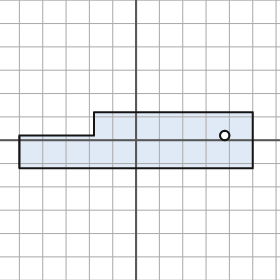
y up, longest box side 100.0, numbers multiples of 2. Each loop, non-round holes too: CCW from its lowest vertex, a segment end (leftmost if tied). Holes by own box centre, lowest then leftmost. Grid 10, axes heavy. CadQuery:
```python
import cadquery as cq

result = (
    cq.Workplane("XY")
    .moveTo(-50.0, -12.0)
    .lineTo(50.0, -12.0)
    .lineTo(50.0, 12.0)
    .lineTo(-18.0, 12.0)
    .lineTo(-18.0, 2.0)
    .lineTo(-50.0, 2.0)
    .close()
    .moveTo(38.0, 2.0)
    .circle(2.0)
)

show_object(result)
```